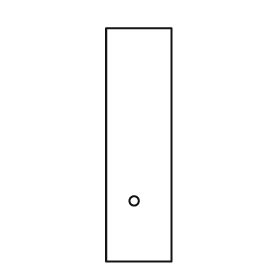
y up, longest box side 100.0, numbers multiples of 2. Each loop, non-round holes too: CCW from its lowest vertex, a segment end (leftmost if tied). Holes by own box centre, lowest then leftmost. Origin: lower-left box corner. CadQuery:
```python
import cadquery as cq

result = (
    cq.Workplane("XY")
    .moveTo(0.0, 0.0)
    .lineTo(28.0, 0.0)
    .lineTo(28.0, 100.0)
    .lineTo(0.0, 100.0)
    .close()
    .moveTo(12.0, 26.0)
    .circle(2.0)
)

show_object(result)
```